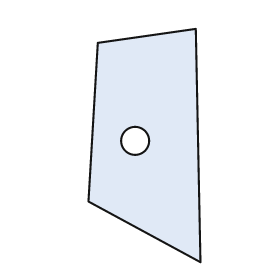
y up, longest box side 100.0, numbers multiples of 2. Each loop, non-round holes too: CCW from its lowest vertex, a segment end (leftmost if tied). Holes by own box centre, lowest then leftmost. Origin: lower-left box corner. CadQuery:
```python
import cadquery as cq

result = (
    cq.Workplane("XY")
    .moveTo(48.0, 0.0)
    .lineTo(46.0, 100.0)
    .lineTo(4.0, 94.0)
    .lineTo(0.0, 26.0)
    .close()
    .moveTo(20.0, 52.0)
    .circle(6.0)
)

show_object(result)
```